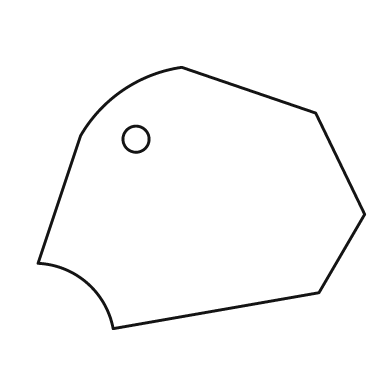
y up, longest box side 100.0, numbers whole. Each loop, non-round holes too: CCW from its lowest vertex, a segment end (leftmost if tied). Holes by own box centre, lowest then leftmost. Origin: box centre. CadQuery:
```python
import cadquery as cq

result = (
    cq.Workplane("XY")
    .moveTo(-27.0, -40.0)
    .lineTo(36.0, -29.0)
    .lineTo(50.0, -5.0)
    .lineTo(35.0, 26.0)
    .lineTo(-6.0, 40.0)
    .threePointArc((-24.0, 33.0), (-37.0, 19.0))
    .lineTo(-50.0, -20.0)
    .threePointArc((-35.0, -26.0), (-27.0, -40.0))
    .close()
    .moveTo(-20.0, 18.0)
    .circle(4.0)
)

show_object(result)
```